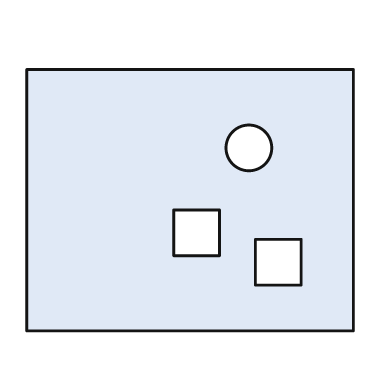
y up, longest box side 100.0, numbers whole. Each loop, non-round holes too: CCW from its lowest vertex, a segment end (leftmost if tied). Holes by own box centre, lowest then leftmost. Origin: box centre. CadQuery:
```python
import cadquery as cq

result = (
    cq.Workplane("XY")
    .moveTo(-50.0, -40.0)
    .lineTo(50.0, -40.0)
    .lineTo(50.0, 40.0)
    .lineTo(-50.0, 40.0)
    .close()
    .moveTo(20.0, -26.0)
    .lineTo(34.0, -26.0)
    .lineTo(34.0, -12.0)
    .lineTo(20.0, -12.0)
    .close()
    .moveTo(-5.0, -17.0)
    .lineTo(9.0, -17.0)
    .lineTo(9.0, -3.0)
    .lineTo(-5.0, -3.0)
    .close()
    .moveTo(18.0, 16.0)
    .circle(7.0)
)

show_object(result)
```